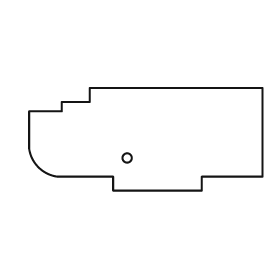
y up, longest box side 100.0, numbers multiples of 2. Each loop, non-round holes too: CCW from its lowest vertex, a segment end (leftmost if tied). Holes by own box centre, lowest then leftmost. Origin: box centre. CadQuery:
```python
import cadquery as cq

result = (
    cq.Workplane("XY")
    .moveTo(-14.0, -22.0)
    .lineTo(24.0, -22.0)
    .lineTo(24.0, -16.0)
    .lineTo(50.0, -16.0)
    .lineTo(50.0, 22.0)
    .lineTo(-24.0, 22.0)
    .lineTo(-24.0, 16.0)
    .lineTo(-36.0, 16.0)
    .lineTo(-36.0, 12.0)
    .lineTo(-50.0, 12.0)
    .lineTo(-50.0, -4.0)
    .threePointArc((-46.0, -12.0), (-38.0, -16.0))
    .lineTo(-14.0, -16.0)
    .close()
    .moveTo(-8.0, -8.0)
    .circle(2.0)
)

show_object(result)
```